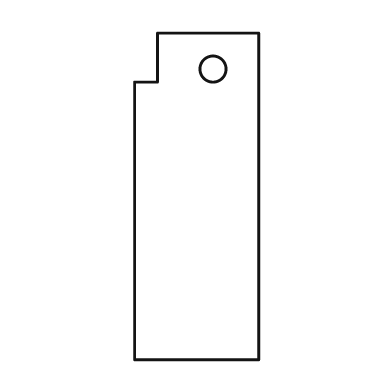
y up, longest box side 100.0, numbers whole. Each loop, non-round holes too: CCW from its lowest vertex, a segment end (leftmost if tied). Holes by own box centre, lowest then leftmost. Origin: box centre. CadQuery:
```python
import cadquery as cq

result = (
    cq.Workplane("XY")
    .moveTo(-19.0, -50.0)
    .lineTo(19.0, -50.0)
    .lineTo(19.0, 50.0)
    .lineTo(-12.0, 50.0)
    .lineTo(-12.0, 35.0)
    .lineTo(-19.0, 35.0)
    .close()
    .moveTo(5.0, 39.0)
    .circle(4.0)
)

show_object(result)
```